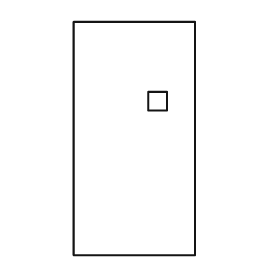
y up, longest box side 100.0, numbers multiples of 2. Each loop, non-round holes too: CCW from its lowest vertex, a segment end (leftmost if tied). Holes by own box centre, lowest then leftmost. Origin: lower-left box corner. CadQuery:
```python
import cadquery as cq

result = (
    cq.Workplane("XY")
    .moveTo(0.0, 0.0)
    .lineTo(52.0, 0.0)
    .lineTo(52.0, 100.0)
    .lineTo(0.0, 100.0)
    .close()
    .moveTo(32.0, 62.0)
    .lineTo(40.0, 62.0)
    .lineTo(40.0, 70.0)
    .lineTo(32.0, 70.0)
    .close()
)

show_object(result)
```